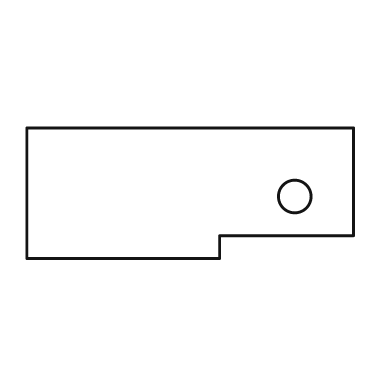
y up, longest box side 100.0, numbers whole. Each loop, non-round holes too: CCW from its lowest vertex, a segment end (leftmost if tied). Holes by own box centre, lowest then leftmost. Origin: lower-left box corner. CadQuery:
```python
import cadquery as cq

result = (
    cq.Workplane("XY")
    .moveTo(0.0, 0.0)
    .lineTo(59.0, 0.0)
    .lineTo(59.0, 7.0)
    .lineTo(100.0, 7.0)
    .lineTo(100.0, 40.0)
    .lineTo(0.0, 40.0)
    .close()
    .moveTo(82.0, 19.0)
    .circle(5.0)
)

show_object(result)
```